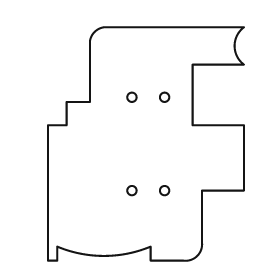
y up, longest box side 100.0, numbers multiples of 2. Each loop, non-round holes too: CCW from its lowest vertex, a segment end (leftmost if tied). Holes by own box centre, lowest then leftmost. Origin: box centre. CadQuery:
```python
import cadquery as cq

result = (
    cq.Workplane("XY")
    .moveTo(-42.0, -50.0)
    .lineTo(-38.0, -50.0)
    .lineTo(-38.0, -44.0)
    .threePointArc((-18.0, -48.0), (2.0, -44.0))
    .lineTo(2.0, -50.0)
    .lineTo(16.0, -50.0)
    .threePointArc((22.0, -48.0), (24.0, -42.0))
    .lineTo(24.0, -20.0)
    .lineTo(42.0, -20.0)
    .lineTo(42.0, 8.0)
    .lineTo(20.0, 8.0)
    .lineTo(20.0, 34.0)
    .lineTo(42.0, 34.0)
    .threePointArc((38.0, 42.0), (42.0, 50.0))
    .lineTo(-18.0, 50.0)
    .threePointArc((-22.0, 48.0), (-24.0, 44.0))
    .lineTo(-24.0, 18.0)
    .lineTo(-34.0, 18.0)
    .lineTo(-34.0, 8.0)
    .lineTo(-42.0, 8.0)
    .close()
    .moveTo(-6.0, -20.0)
    .circle(2.0)
    .moveTo(8.0, -20.0)
    .circle(2.0)
    .moveTo(-6.0, 20.0)
    .circle(2.0)
    .moveTo(8.0, 20.0)
    .circle(2.0)
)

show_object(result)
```